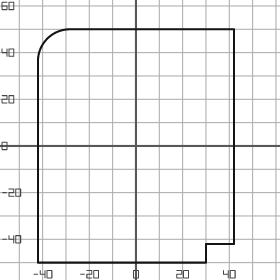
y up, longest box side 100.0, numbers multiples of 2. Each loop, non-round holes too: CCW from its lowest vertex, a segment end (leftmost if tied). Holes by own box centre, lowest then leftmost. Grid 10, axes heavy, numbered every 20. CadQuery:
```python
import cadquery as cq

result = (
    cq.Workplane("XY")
    .moveTo(-42.0, -50.0)
    .lineTo(30.0, -50.0)
    .lineTo(30.0, -42.0)
    .lineTo(42.0, -42.0)
    .lineTo(42.0, 50.0)
    .lineTo(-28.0, 50.0)
    .threePointArc((-38.0, 46.0), (-42.0, 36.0))
    .close()
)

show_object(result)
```